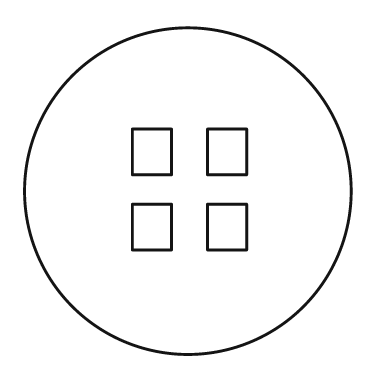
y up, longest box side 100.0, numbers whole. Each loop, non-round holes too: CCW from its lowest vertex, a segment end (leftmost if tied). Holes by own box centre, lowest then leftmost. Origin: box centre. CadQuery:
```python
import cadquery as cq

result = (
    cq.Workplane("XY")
    .moveTo(0.0, 0.0)
    .circle(50.0)
    .moveTo(-17.0, -18.0)
    .lineTo(-5.0, -18.0)
    .lineTo(-5.0, -4.0)
    .lineTo(-17.0, -4.0)
    .close()
    .moveTo(6.0, -18.0)
    .lineTo(18.0, -18.0)
    .lineTo(18.0, -4.0)
    .lineTo(6.0, -4.0)
    .close()
    .moveTo(-17.0, 5.0)
    .lineTo(-5.0, 5.0)
    .lineTo(-5.0, 19.0)
    .lineTo(-17.0, 19.0)
    .close()
    .moveTo(6.0, 5.0)
    .lineTo(18.0, 5.0)
    .lineTo(18.0, 19.0)
    .lineTo(6.0, 19.0)
    .close()
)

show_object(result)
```